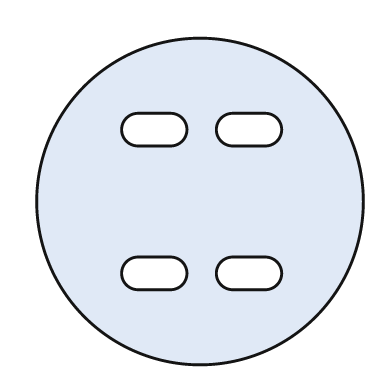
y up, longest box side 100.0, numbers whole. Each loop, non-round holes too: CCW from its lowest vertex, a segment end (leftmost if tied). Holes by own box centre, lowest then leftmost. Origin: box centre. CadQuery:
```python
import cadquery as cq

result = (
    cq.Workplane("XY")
    .moveTo(0.0, 0.0)
    .circle(50.0)
    .moveTo(-19.0, -27.0)
    .lineTo(-9.0, -27.0)
    .threePointArc((-4.0, -22.0), (-9.0, -17.0))
    .lineTo(-19.0, -17.0)
    .threePointArc((-24.0, -22.0), (-19.0, -27.0))
    .close()
    .moveTo(10.0, -27.0)
    .lineTo(20.0, -27.0)
    .threePointArc((25.0, -22.0), (20.0, -17.0))
    .lineTo(10.0, -17.0)
    .threePointArc((5.0, -22.0), (10.0, -27.0))
    .close()
    .moveTo(-19.0, 17.0)
    .lineTo(-9.0, 17.0)
    .threePointArc((-4.0, 22.0), (-9.0, 27.0))
    .lineTo(-19.0, 27.0)
    .threePointArc((-24.0, 22.0), (-19.0, 17.0))
    .close()
    .moveTo(10.0, 17.0)
    .lineTo(20.0, 17.0)
    .threePointArc((25.0, 22.0), (20.0, 27.0))
    .lineTo(10.0, 27.0)
    .threePointArc((5.0, 22.0), (10.0, 17.0))
    .close()
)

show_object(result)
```